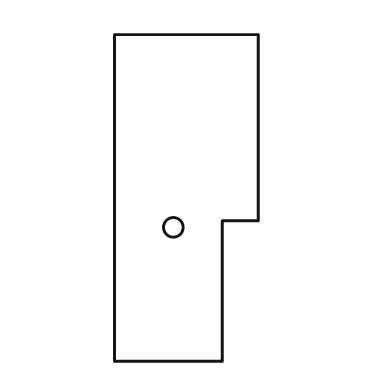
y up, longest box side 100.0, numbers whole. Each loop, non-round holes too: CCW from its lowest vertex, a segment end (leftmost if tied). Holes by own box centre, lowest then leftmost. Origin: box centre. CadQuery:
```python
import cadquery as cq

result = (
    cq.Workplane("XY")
    .moveTo(-22.0, -50.0)
    .lineTo(11.0, -50.0)
    .lineTo(11.0, -7.0)
    .lineTo(22.0, -7.0)
    .lineTo(22.0, 50.0)
    .lineTo(-22.0, 50.0)
    .close()
    .moveTo(-4.0, -9.0)
    .circle(3.0)
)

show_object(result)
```